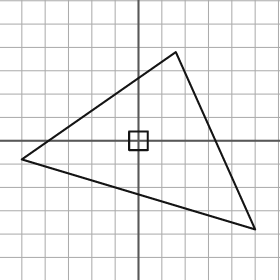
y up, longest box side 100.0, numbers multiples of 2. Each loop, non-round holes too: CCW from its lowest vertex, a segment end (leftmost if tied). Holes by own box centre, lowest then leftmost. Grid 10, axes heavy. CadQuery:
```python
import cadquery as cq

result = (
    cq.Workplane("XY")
    .moveTo(50.0, -38.0)
    .lineTo(16.0, 38.0)
    .lineTo(-50.0, -8.0)
    .close()
    .moveTo(-4.0, -4.0)
    .lineTo(4.0, -4.0)
    .lineTo(4.0, 4.0)
    .lineTo(-4.0, 4.0)
    .close()
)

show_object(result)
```